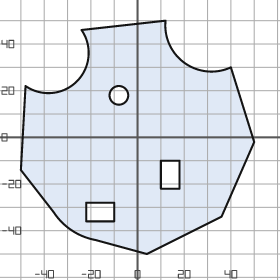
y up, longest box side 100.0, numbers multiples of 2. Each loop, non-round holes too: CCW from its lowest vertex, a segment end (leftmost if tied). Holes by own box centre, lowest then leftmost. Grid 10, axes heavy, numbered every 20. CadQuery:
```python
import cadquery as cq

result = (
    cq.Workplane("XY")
    .moveTo(4.0, -50.0)
    .lineTo(36.0, -34.0)
    .lineTo(50.0, -2.0)
    .lineTo(40.0, 30.0)
    .threePointArc((20.0, 32.0), (12.0, 50.0))
    .lineTo(-24.0, 46.0)
    .threePointArc((-26.0, 24.0), (-48.0, 22.0))
    .lineTo(-50.0, -14.0)
    .lineTo(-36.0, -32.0)
    .threePointArc((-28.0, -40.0), (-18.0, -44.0))
    .close()
    .moveTo(-22.0, -36.0)
    .lineTo(-10.0, -36.0)
    .lineTo(-10.0, -28.0)
    .lineTo(-22.0, -28.0)
    .close()
    .moveTo(10.0, -22.0)
    .lineTo(18.0, -22.0)
    .lineTo(18.0, -10.0)
    .lineTo(10.0, -10.0)
    .close()
    .moveTo(-8.0, 18.0)
    .circle(4.0)
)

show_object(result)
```